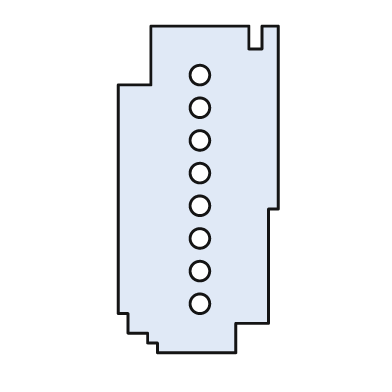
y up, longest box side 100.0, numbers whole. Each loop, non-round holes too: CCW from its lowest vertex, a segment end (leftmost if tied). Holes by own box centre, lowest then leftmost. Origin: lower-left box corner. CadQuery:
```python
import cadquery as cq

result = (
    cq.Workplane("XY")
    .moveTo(12.0, 0.0)
    .lineTo(36.0, 0.0)
    .lineTo(36.0, 9.0)
    .lineTo(46.0, 9.0)
    .lineTo(46.0, 44.0)
    .lineTo(49.0, 44.0)
    .lineTo(49.0, 100.0)
    .lineTo(44.0, 100.0)
    .lineTo(44.0, 93.0)
    .lineTo(40.0, 93.0)
    .lineTo(40.0, 100.0)
    .lineTo(10.0, 100.0)
    .lineTo(10.0, 82.0)
    .lineTo(0.0, 82.0)
    .lineTo(0.0, 12.0)
    .lineTo(3.0, 12.0)
    .lineTo(3.0, 6.0)
    .lineTo(9.0, 6.0)
    .lineTo(9.0, 3.0)
    .lineTo(12.0, 3.0)
    .close()
    .moveTo(25.0, 15.0)
    .circle(3.0)
    .moveTo(25.0, 25.0)
    .circle(3.0)
    .moveTo(25.0, 35.0)
    .circle(3.0)
    .moveTo(25.0, 45.0)
    .circle(3.0)
    .moveTo(25.0, 55.0)
    .circle(3.0)
    .moveTo(25.0, 65.0)
    .circle(3.0)
    .moveTo(25.0, 75.0)
    .circle(3.0)
    .moveTo(25.0, 85.0)
    .circle(3.0)
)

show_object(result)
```